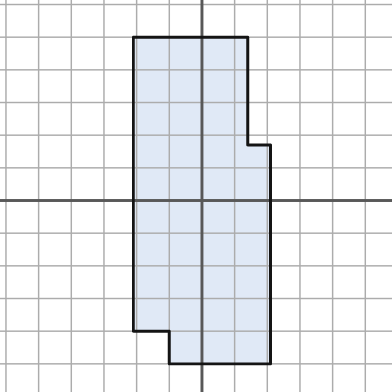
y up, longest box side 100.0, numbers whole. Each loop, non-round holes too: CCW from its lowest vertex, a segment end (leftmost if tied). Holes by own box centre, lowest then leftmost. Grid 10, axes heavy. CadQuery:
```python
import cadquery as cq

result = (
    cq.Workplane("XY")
    .moveTo(-10.0, -50.0)
    .lineTo(21.0, -50.0)
    .lineTo(21.0, 17.0)
    .lineTo(14.0, 17.0)
    .lineTo(14.0, 50.0)
    .lineTo(-21.0, 50.0)
    .lineTo(-21.0, -40.0)
    .lineTo(-10.0, -40.0)
    .close()
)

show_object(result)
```